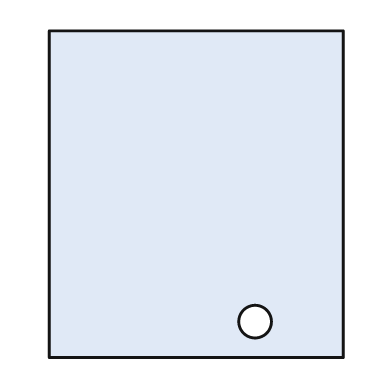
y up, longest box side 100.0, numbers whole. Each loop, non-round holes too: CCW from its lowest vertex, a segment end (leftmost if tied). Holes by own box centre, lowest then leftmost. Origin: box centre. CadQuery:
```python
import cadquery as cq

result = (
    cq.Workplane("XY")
    .moveTo(-45.0, -50.0)
    .lineTo(45.0, -50.0)
    .lineTo(45.0, 50.0)
    .lineTo(-45.0, 50.0)
    .close()
    .moveTo(18.0, -39.0)
    .circle(5.0)
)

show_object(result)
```